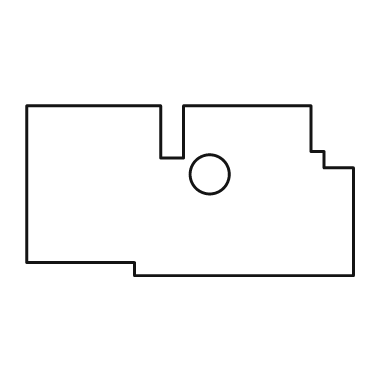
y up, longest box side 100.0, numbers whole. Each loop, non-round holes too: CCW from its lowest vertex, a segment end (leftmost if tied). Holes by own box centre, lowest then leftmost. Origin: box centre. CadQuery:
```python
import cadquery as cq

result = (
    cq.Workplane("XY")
    .moveTo(-17.0, -26.0)
    .lineTo(50.0, -26.0)
    .lineTo(50.0, 7.0)
    .lineTo(41.0, 7.0)
    .lineTo(41.0, 12.0)
    .lineTo(37.0, 12.0)
    .lineTo(37.0, 26.0)
    .lineTo(-2.0, 26.0)
    .lineTo(-2.0, 10.0)
    .lineTo(-9.0, 10.0)
    .lineTo(-9.0, 26.0)
    .lineTo(-50.0, 26.0)
    .lineTo(-50.0, -22.0)
    .lineTo(-17.0, -22.0)
    .close()
    .moveTo(6.0, 5.0)
    .circle(6.0)
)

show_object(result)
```